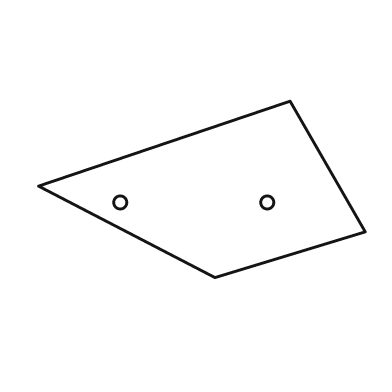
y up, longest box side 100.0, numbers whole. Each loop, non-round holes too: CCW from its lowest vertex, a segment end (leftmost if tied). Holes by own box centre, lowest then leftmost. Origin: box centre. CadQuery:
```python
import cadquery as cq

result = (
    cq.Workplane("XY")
    .moveTo(4.0, -27.0)
    .lineTo(50.0, -13.0)
    .lineTo(27.0, 27.0)
    .lineTo(-50.0, 1.0)
    .close()
    .moveTo(-25.0, -4.0)
    .circle(2.0)
    .moveTo(20.0, -4.0)
    .circle(2.0)
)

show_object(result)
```